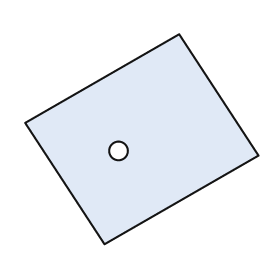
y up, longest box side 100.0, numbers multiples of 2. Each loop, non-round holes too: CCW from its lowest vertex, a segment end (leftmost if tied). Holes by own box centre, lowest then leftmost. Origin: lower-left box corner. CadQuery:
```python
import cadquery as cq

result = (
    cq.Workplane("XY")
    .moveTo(34.0, 0.0)
    .lineTo(100.0, 38.0)
    .lineTo(66.0, 90.0)
    .lineTo(0.0, 52.0)
    .close()
    .moveTo(40.0, 40.0)
    .circle(4.0)
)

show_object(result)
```